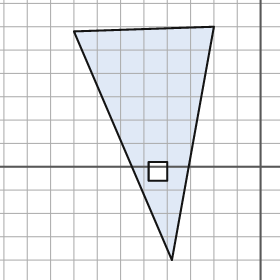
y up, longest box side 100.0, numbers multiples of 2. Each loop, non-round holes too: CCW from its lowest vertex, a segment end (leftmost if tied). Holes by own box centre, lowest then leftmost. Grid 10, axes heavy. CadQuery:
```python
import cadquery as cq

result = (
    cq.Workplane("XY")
    .moveTo(-38.0, -40.0)
    .lineTo(-20.0, 60.0)
    .lineTo(-80.0, 58.0)
    .close()
    .moveTo(-48.0, -6.0)
    .lineTo(-40.0, -6.0)
    .lineTo(-40.0, 2.0)
    .lineTo(-48.0, 2.0)
    .close()
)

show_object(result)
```